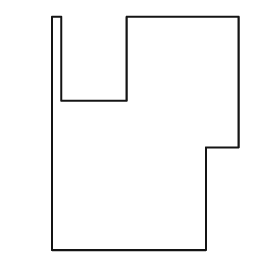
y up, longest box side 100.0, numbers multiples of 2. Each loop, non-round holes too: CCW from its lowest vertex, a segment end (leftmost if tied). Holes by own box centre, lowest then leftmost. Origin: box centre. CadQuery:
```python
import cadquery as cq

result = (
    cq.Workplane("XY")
    .moveTo(-40.0, -50.0)
    .lineTo(26.0, -50.0)
    .lineTo(26.0, -6.0)
    .lineTo(40.0, -6.0)
    .lineTo(40.0, 50.0)
    .lineTo(-8.0, 50.0)
    .lineTo(-8.0, 14.0)
    .lineTo(-36.0, 14.0)
    .lineTo(-36.0, 50.0)
    .lineTo(-40.0, 50.0)
    .close()
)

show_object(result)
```